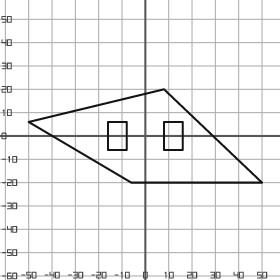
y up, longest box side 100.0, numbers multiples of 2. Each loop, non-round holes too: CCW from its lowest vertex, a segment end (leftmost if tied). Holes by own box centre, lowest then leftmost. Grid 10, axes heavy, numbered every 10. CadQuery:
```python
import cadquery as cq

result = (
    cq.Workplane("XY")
    .moveTo(-6.0, -20.0)
    .lineTo(50.0, -20.0)
    .lineTo(8.0, 20.0)
    .lineTo(-50.0, 6.0)
    .close()
    .moveTo(-16.0, -6.0)
    .lineTo(-8.0, -6.0)
    .lineTo(-8.0, 6.0)
    .lineTo(-16.0, 6.0)
    .close()
    .moveTo(8.0, -6.0)
    .lineTo(16.0, -6.0)
    .lineTo(16.0, 6.0)
    .lineTo(8.0, 6.0)
    .close()
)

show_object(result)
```